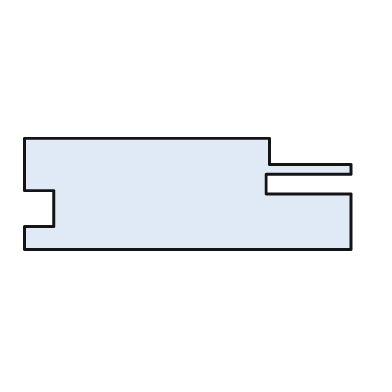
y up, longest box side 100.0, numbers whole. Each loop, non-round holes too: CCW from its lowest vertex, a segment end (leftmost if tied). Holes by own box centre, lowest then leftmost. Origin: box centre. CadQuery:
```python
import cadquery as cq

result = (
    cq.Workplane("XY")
    .moveTo(-50.0, -17.0)
    .lineTo(50.0, -17.0)
    .lineTo(50.0, 0.0)
    .lineTo(24.0, 0.0)
    .lineTo(24.0, 6.0)
    .lineTo(50.0, 6.0)
    .lineTo(50.0, 9.0)
    .lineTo(25.0, 9.0)
    .lineTo(25.0, 17.0)
    .lineTo(-50.0, 17.0)
    .lineTo(-50.0, 1.0)
    .lineTo(-41.0, 1.0)
    .lineTo(-41.0, -10.0)
    .lineTo(-50.0, -10.0)
    .close()
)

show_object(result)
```